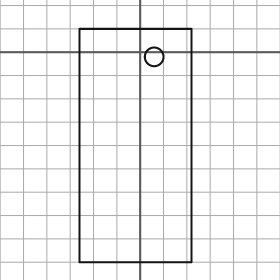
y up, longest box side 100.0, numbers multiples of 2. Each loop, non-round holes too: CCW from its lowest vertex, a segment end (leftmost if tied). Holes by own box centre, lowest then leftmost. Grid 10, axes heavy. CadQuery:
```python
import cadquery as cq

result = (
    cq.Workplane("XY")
    .moveTo(-26.0, -90.0)
    .lineTo(22.0, -90.0)
    .lineTo(22.0, 10.0)
    .lineTo(-26.0, 10.0)
    .close()
    .moveTo(6.0, -2.0)
    .circle(4.0)
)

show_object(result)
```